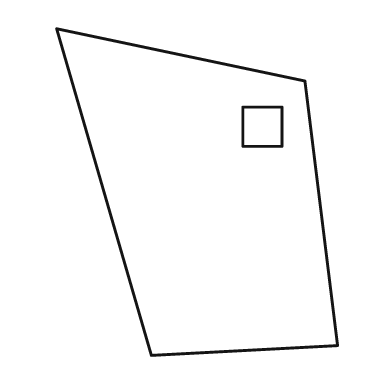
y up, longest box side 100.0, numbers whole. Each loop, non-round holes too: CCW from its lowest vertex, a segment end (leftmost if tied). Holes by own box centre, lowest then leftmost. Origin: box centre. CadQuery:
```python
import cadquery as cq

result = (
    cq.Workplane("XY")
    .moveTo(-14.0, -50.0)
    .lineTo(43.0, -47.0)
    .lineTo(33.0, 34.0)
    .lineTo(-43.0, 50.0)
    .close()
    .moveTo(14.0, 14.0)
    .lineTo(26.0, 14.0)
    .lineTo(26.0, 26.0)
    .lineTo(14.0, 26.0)
    .close()
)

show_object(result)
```